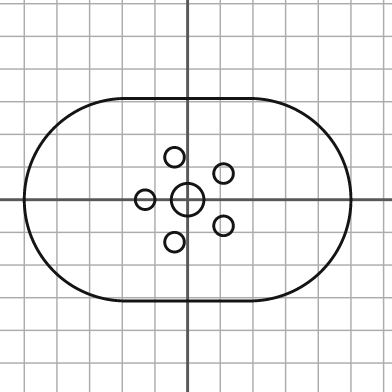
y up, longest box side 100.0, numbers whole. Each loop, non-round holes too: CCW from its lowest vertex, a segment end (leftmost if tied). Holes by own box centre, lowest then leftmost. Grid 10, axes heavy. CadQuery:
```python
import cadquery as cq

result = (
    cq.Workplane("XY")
    .moveTo(-19.0, -31.0)
    .lineTo(19.0, -31.0)
    .threePointArc((50.0, 0.0), (19.0, 31.0))
    .lineTo(-19.0, 31.0)
    .threePointArc((-50.0, 0.0), (-19.0, -31.0))
    .close()
    .moveTo(-4.0, -13.0)
    .circle(3.0)
    .moveTo(11.0, -8.0)
    .circle(3.0)
    .moveTo(-13.0, 0.0)
    .circle(3.0)
    .moveTo(0.0, 0.0)
    .circle(5.0)
    .moveTo(11.0, 8.0)
    .circle(3.0)
    .moveTo(-4.0, 13.0)
    .circle(3.0)
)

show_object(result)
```